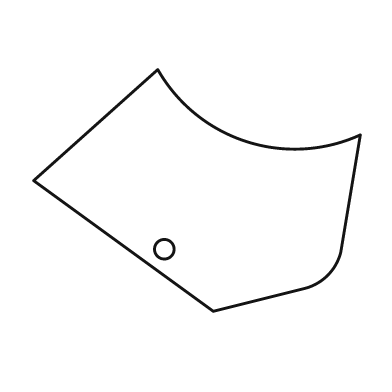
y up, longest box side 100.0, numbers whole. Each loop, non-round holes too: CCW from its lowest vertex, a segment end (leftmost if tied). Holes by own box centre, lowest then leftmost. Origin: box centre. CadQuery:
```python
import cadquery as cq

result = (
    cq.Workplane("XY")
    .moveTo(5.0, -37.0)
    .lineTo(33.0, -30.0)
    .threePointArc((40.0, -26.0), (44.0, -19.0))
    .lineTo(50.0, 17.0)
    .threePointArc((15.0, 15.0), (-12.0, 37.0))
    .lineTo(-50.0, 3.0)
    .close()
    .moveTo(-10.0, -18.0)
    .circle(3.0)
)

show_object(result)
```